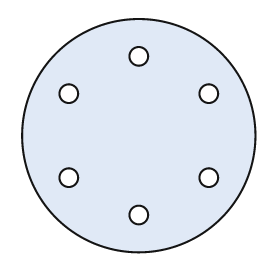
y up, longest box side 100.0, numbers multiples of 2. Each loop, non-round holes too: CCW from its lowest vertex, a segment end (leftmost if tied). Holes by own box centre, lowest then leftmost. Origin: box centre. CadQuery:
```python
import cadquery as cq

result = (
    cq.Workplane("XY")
    .moveTo(0.0, 0.0)
    .circle(50.0)
    .moveTo(0.0, -34.0)
    .circle(4.0)
    .moveTo(-30.0, -18.0)
    .circle(4.0)
    .moveTo(30.0, -18.0)
    .circle(4.0)
    .moveTo(-30.0, 18.0)
    .circle(4.0)
    .moveTo(30.0, 18.0)
    .circle(4.0)
    .moveTo(0.0, 34.0)
    .circle(4.0)
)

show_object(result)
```